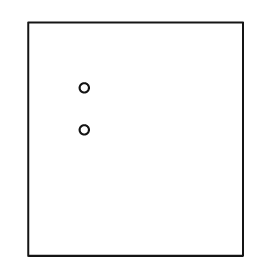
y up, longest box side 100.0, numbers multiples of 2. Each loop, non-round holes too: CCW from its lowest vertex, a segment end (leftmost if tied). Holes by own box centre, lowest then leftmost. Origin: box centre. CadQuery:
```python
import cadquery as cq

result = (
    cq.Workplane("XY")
    .moveTo(-46.0, -50.0)
    .lineTo(46.0, -50.0)
    .lineTo(46.0, 50.0)
    .lineTo(-46.0, 50.0)
    .close()
    .moveTo(-22.0, 4.0)
    .circle(2.0)
    .moveTo(-22.0, 22.0)
    .circle(2.0)
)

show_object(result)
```